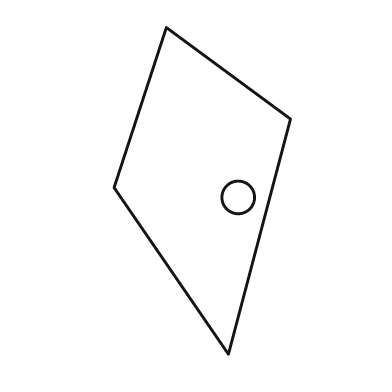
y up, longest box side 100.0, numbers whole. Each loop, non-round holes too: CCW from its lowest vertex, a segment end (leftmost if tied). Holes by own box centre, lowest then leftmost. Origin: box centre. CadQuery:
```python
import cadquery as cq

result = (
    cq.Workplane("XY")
    .moveTo(8.0, -50.0)
    .lineTo(27.0, 22.0)
    .lineTo(-11.0, 50.0)
    .lineTo(-27.0, 1.0)
    .close()
    .moveTo(11.0, -2.0)
    .circle(5.0)
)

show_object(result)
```